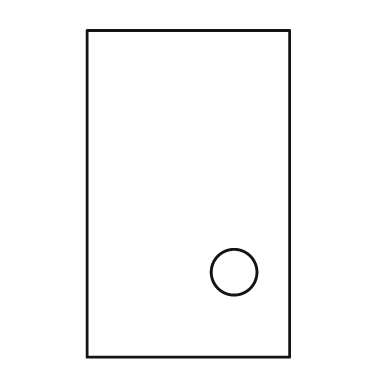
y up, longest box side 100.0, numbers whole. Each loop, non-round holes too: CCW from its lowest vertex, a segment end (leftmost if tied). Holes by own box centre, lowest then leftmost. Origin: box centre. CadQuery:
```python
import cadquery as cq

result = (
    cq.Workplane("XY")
    .moveTo(-31.0, -50.0)
    .lineTo(31.0, -50.0)
    .lineTo(31.0, 50.0)
    .lineTo(-31.0, 50.0)
    .close()
    .moveTo(14.0, -24.0)
    .circle(7.0)
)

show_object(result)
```